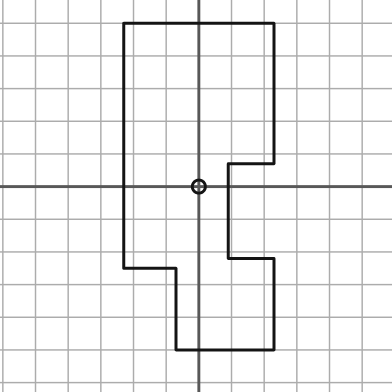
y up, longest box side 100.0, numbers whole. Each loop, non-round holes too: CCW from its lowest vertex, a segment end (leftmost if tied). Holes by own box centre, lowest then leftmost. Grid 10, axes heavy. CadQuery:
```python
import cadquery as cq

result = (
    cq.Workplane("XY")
    .moveTo(-7.0, -50.0)
    .lineTo(23.0, -50.0)
    .lineTo(23.0, -22.0)
    .lineTo(9.0, -22.0)
    .lineTo(9.0, 7.0)
    .lineTo(23.0, 7.0)
    .lineTo(23.0, 50.0)
    .lineTo(-23.0, 50.0)
    .lineTo(-23.0, -25.0)
    .lineTo(-7.0, -25.0)
    .close()
    .moveTo(0.0, 0.0)
    .circle(2.0)
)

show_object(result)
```